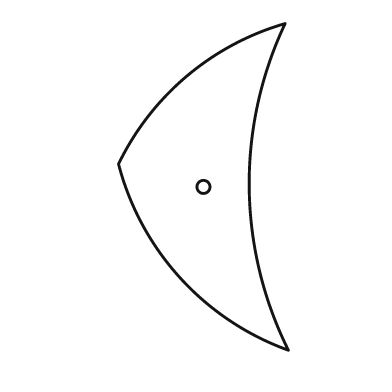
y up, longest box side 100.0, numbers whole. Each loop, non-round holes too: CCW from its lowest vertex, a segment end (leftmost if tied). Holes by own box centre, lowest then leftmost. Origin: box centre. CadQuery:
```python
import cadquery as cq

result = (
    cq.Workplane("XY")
    .moveTo(26.0, -50.0)
    .threePointArc((14.0, 0.0), (25.0, 50.0))
    .threePointArc((-5.0, 34.0), (-26.0, 7.0))
    .threePointArc((-7.0, -28.0), (26.0, -50.0))
    .close()
    .moveTo(0.0, 0.0)
    .circle(2.0)
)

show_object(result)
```